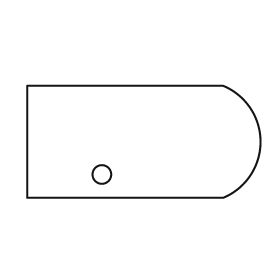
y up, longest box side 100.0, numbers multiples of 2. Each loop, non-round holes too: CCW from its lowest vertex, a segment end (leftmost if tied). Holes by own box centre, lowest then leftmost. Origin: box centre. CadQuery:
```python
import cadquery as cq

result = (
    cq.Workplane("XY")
    .moveTo(-50.0, -24.0)
    .lineTo(34.0, -24.0)
    .threePointArc((50.0, 0.0), (34.0, 24.0))
    .lineTo(-50.0, 24.0)
    .close()
    .moveTo(-18.0, -14.0)
    .circle(4.0)
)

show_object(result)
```